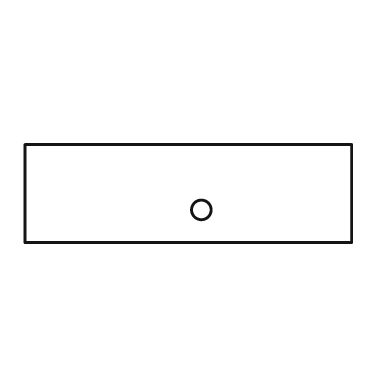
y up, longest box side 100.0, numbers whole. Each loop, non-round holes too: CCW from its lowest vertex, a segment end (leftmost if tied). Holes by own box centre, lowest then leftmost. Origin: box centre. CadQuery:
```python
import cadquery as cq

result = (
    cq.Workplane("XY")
    .moveTo(-50.0, -15.0)
    .lineTo(50.0, -15.0)
    .lineTo(50.0, 15.0)
    .lineTo(-50.0, 15.0)
    .close()
    .moveTo(4.0, -5.0)
    .circle(3.0)
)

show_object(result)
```